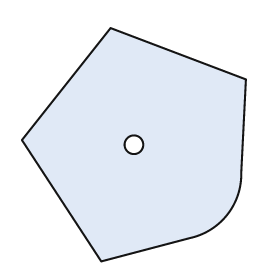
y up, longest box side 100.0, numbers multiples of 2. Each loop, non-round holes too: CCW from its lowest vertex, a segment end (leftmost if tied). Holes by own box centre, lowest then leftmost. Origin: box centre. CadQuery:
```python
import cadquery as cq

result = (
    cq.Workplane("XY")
    .moveTo(-14.0, -50.0)
    .lineTo(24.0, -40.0)
    .threePointArc((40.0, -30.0), (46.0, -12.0))
    .lineTo(48.0, 28.0)
    .lineTo(-10.0, 50.0)
    .lineTo(-48.0, 2.0)
    .close()
    .moveTo(0.0, 0.0)
    .circle(4.0)
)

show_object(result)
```